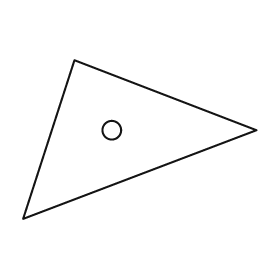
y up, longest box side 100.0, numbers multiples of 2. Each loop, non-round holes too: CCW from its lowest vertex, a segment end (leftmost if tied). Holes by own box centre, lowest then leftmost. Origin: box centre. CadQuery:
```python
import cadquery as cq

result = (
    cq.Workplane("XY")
    .moveTo(-50.0, -34.0)
    .lineTo(50.0, 4.0)
    .lineTo(-28.0, 34.0)
    .close()
    .moveTo(-12.0, 4.0)
    .circle(4.0)
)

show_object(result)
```